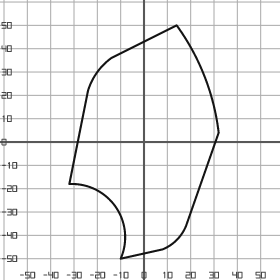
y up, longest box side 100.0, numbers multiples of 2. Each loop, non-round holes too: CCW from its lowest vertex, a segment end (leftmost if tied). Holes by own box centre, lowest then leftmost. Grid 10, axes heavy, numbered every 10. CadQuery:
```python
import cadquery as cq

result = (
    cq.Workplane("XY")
    .moveTo(-10.0, -50.0)
    .lineTo(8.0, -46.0)
    .threePointArc((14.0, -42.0), (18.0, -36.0))
    .lineTo(32.0, 4.0)
    .threePointArc((26.0, 28.0), (14.0, 50.0))
    .lineTo(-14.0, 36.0)
    .threePointArc((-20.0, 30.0), (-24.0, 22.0))
    .lineTo(-32.0, -18.0)
    .threePointArc((-12.0, -28.0), (-10.0, -50.0))
    .close()
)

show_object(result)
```